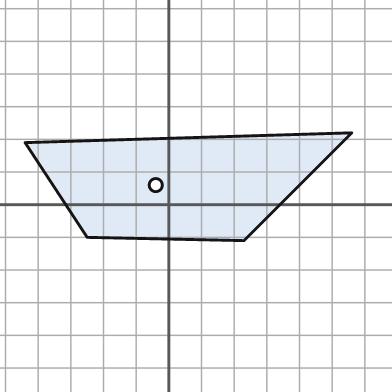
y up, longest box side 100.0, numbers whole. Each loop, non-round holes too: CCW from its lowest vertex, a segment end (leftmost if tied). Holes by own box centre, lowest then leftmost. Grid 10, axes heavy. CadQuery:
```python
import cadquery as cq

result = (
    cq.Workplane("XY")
    .moveTo(23.0, -11.0)
    .lineTo(56.0, 22.0)
    .lineTo(-44.0, 19.0)
    .lineTo(-25.0, -10.0)
    .close()
    .moveTo(-4.0, 6.0)
    .circle(2.0)
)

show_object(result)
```